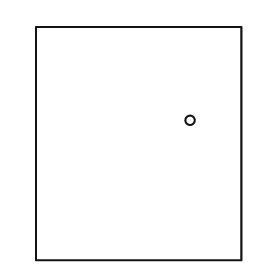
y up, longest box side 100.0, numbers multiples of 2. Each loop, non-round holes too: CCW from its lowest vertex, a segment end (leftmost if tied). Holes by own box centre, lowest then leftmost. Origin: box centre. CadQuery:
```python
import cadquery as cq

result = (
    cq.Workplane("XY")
    .moveTo(-44.0, -50.0)
    .lineTo(44.0, -50.0)
    .lineTo(44.0, 50.0)
    .lineTo(-44.0, 50.0)
    .close()
    .moveTo(22.0, 10.0)
    .circle(2.0)
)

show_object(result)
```